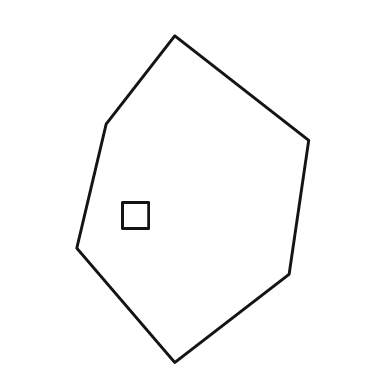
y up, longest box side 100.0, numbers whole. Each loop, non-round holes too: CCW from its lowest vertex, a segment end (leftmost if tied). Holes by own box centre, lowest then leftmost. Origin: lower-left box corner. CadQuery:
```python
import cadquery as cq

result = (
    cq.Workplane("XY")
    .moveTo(30.0, 0.0)
    .lineTo(65.0, 27.0)
    .lineTo(71.0, 68.0)
    .lineTo(30.0, 100.0)
    .lineTo(9.0, 73.0)
    .lineTo(0.0, 35.0)
    .close()
    .moveTo(14.0, 41.0)
    .lineTo(22.0, 41.0)
    .lineTo(22.0, 49.0)
    .lineTo(14.0, 49.0)
    .close()
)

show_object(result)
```